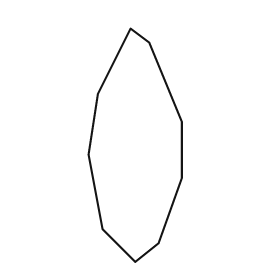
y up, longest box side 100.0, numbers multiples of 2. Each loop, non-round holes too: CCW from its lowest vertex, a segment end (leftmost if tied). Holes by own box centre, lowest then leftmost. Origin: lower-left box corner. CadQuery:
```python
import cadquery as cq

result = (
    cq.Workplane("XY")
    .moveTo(20.0, 0.0)
    .lineTo(30.0, 8.0)
    .lineTo(40.0, 36.0)
    .lineTo(40.0, 60.0)
    .lineTo(26.0, 94.0)
    .lineTo(18.0, 100.0)
    .lineTo(4.0, 72.0)
    .lineTo(0.0, 46.0)
    .lineTo(6.0, 14.0)
    .close()
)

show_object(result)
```